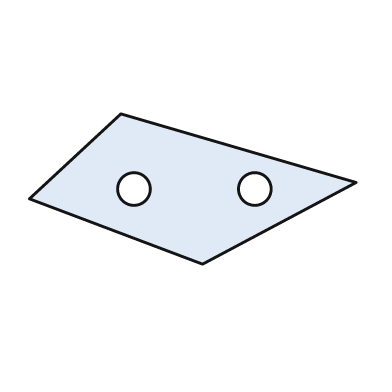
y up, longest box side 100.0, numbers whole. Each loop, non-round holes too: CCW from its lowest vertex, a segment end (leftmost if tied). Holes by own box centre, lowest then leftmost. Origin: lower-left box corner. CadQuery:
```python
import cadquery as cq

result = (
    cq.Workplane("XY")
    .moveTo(53.0, 0.0)
    .lineTo(100.0, 25.0)
    .lineTo(28.0, 46.0)
    .lineTo(0.0, 20.0)
    .close()
    .moveTo(32.0, 23.0)
    .circle(5.0)
    .moveTo(69.0, 23.0)
    .circle(5.0)
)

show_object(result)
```